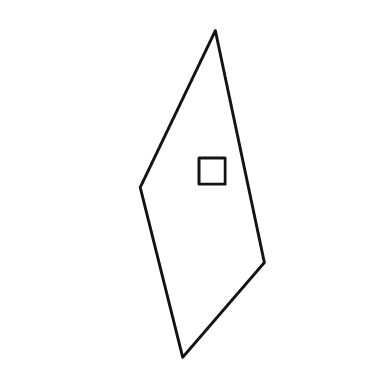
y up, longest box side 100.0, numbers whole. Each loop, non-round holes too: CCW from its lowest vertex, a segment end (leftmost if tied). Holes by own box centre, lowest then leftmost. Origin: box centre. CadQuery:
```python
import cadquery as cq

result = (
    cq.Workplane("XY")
    .moveTo(-6.0, -50.0)
    .lineTo(19.0, -21.0)
    .lineTo(4.0, 50.0)
    .lineTo(-19.0, 2.0)
    .close()
    .moveTo(-1.0, 3.0)
    .lineTo(7.0, 3.0)
    .lineTo(7.0, 11.0)
    .lineTo(-1.0, 11.0)
    .close()
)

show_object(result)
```